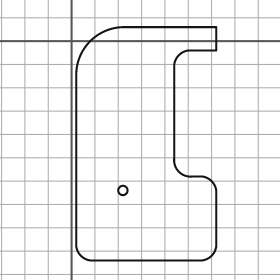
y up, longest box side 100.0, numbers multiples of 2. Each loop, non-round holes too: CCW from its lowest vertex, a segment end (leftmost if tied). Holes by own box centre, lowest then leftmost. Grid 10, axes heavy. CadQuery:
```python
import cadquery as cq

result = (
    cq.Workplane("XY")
    .moveTo(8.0, -94.0)
    .lineTo(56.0, -94.0)
    .threePointArc((60.0, -92.0), (62.0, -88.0))
    .lineTo(62.0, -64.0)
    .threePointArc((60.0, -60.0), (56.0, -58.0))
    .lineTo(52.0, -58.0)
    .threePointArc((46.0, -56.0), (44.0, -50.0))
    .lineTo(44.0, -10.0)
    .threePointArc((46.0, -6.0), (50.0, -4.0))
    .lineTo(62.0, -4.0)
    .lineTo(62.0, 6.0)
    .lineTo(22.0, 6.0)
    .threePointArc((8.0, 0.0), (2.0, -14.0))
    .lineTo(2.0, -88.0)
    .threePointArc((4.0, -92.0), (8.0, -94.0))
    .close()
    .moveTo(22.0, -64.0)
    .circle(2.0)
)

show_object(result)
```